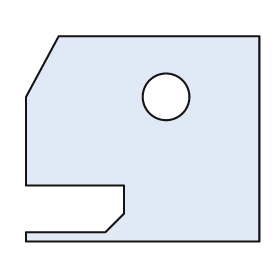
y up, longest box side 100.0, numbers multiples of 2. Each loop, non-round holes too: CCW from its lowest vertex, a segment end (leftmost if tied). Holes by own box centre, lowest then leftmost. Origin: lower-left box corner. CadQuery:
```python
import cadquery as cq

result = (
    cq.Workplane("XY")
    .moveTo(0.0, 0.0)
    .lineTo(100.0, 0.0)
    .lineTo(100.0, 88.0)
    .lineTo(14.0, 88.0)
    .lineTo(0.0, 62.0)
    .lineTo(0.0, 24.0)
    .lineTo(42.0, 24.0)
    .lineTo(42.0, 12.0)
    .lineTo(34.0, 4.0)
    .lineTo(0.0, 4.0)
    .close()
    .moveTo(60.0, 62.0)
    .circle(10.0)
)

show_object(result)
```